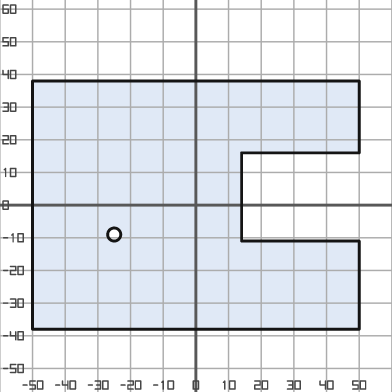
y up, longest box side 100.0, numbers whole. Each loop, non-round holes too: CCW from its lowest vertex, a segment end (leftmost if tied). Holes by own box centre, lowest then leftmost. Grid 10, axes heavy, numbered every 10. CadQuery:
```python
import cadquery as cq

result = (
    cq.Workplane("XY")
    .moveTo(-50.0, -38.0)
    .lineTo(50.0, -38.0)
    .lineTo(50.0, -11.0)
    .lineTo(14.0, -11.0)
    .lineTo(14.0, 16.0)
    .lineTo(50.0, 16.0)
    .lineTo(50.0, 38.0)
    .lineTo(-50.0, 38.0)
    .close()
    .moveTo(-25.0, -9.0)
    .circle(2.0)
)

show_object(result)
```